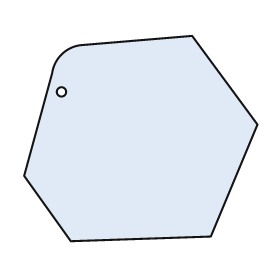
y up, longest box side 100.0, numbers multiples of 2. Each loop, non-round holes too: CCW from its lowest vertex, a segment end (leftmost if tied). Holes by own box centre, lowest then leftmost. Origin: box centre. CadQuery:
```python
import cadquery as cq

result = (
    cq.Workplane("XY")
    .moveTo(-30.0, -44.0)
    .lineTo(30.0, -42.0)
    .lineTo(50.0, 6.0)
    .lineTo(22.0, 44.0)
    .lineTo(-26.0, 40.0)
    .threePointArc((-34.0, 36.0), (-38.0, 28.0))
    .lineTo(-50.0, -16.0)
    .close()
    .moveTo(-34.0, 20.0)
    .circle(2.0)
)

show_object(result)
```